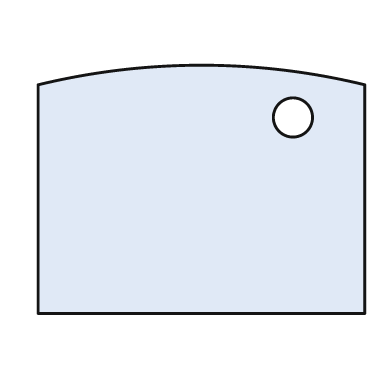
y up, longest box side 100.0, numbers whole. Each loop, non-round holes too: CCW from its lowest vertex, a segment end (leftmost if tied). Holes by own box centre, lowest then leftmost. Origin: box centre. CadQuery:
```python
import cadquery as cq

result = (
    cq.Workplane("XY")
    .moveTo(-50.0, -38.0)
    .lineTo(50.0, -38.0)
    .lineTo(50.0, 32.0)
    .threePointArc((0.0, 38.0), (-50.0, 32.0))
    .close()
    .moveTo(28.0, 22.0)
    .circle(6.0)
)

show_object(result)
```